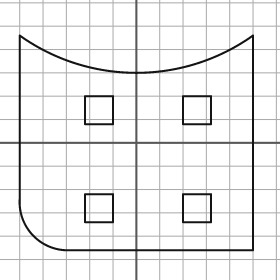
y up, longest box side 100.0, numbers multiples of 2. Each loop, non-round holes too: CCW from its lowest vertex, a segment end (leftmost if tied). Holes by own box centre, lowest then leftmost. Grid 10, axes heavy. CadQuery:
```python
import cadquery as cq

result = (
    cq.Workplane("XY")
    .moveTo(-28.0, -46.0)
    .lineTo(50.0, -46.0)
    .lineTo(50.0, 46.0)
    .threePointArc((0.0, 30.0), (-50.0, 46.0))
    .lineTo(-50.0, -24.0)
    .threePointArc((-44.0, -40.0), (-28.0, -46.0))
    .close()
    .moveTo(-22.0, -34.0)
    .lineTo(-10.0, -34.0)
    .lineTo(-10.0, -22.0)
    .lineTo(-22.0, -22.0)
    .close()
    .moveTo(20.0, -34.0)
    .lineTo(32.0, -34.0)
    .lineTo(32.0, -22.0)
    .lineTo(20.0, -22.0)
    .close()
    .moveTo(-22.0, 8.0)
    .lineTo(-10.0, 8.0)
    .lineTo(-10.0, 20.0)
    .lineTo(-22.0, 20.0)
    .close()
    .moveTo(20.0, 8.0)
    .lineTo(32.0, 8.0)
    .lineTo(32.0, 20.0)
    .lineTo(20.0, 20.0)
    .close()
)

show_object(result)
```